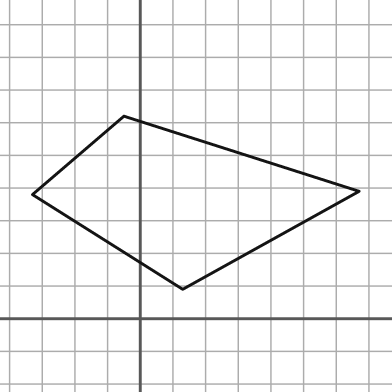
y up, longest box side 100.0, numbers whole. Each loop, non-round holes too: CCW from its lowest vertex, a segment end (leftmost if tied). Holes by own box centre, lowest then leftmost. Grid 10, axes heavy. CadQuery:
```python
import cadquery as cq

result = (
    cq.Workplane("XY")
    .moveTo(13.0, 9.0)
    .lineTo(67.0, 39.0)
    .lineTo(-5.0, 62.0)
    .lineTo(-33.0, 38.0)
    .close()
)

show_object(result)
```